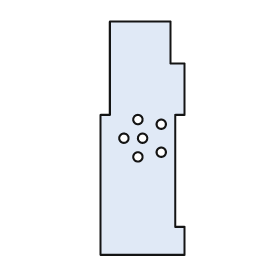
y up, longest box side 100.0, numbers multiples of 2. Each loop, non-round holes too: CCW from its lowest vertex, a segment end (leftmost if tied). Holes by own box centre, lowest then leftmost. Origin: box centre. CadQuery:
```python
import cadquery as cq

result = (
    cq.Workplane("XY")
    .moveTo(-18.0, -50.0)
    .lineTo(18.0, -50.0)
    .lineTo(18.0, -38.0)
    .lineTo(14.0, -38.0)
    .lineTo(14.0, 10.0)
    .lineTo(18.0, 10.0)
    .lineTo(18.0, 32.0)
    .lineTo(12.0, 32.0)
    .lineTo(12.0, 50.0)
    .lineTo(-14.0, 50.0)
    .lineTo(-14.0, 10.0)
    .lineTo(-18.0, 10.0)
    .close()
    .moveTo(-2.0, -8.0)
    .circle(2.0)
    .moveTo(8.0, -6.0)
    .circle(2.0)
    .moveTo(-8.0, 0.0)
    .circle(2.0)
    .moveTo(0.0, 0.0)
    .circle(2.0)
    .moveTo(8.0, 6.0)
    .circle(2.0)
    .moveTo(-2.0, 8.0)
    .circle(2.0)
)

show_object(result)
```